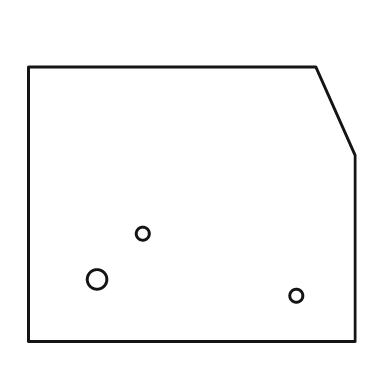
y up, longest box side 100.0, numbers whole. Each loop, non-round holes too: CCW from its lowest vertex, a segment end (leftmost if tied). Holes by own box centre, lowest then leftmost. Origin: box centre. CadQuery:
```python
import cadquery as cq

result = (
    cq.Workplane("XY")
    .moveTo(-50.0, -42.0)
    .lineTo(50.0, -42.0)
    .lineTo(50.0, 15.0)
    .lineTo(38.0, 42.0)
    .lineTo(-50.0, 42.0)
    .close()
    .moveTo(32.0, -28.0)
    .circle(2.0)
    .moveTo(-29.0, -23.0)
    .circle(3.0)
    .moveTo(-15.0, -9.0)
    .circle(2.0)
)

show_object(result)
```